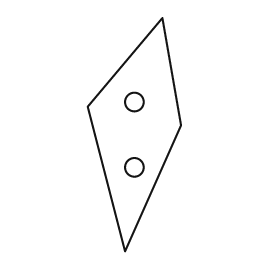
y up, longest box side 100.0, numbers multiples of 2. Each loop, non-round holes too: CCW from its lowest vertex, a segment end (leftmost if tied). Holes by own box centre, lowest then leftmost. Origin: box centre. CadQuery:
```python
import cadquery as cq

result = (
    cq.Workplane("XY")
    .moveTo(-4.0, -50.0)
    .lineTo(20.0, 4.0)
    .lineTo(12.0, 50.0)
    .lineTo(-20.0, 12.0)
    .close()
    .moveTo(0.0, -14.0)
    .circle(4.0)
    .moveTo(0.0, 14.0)
    .circle(4.0)
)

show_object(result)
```